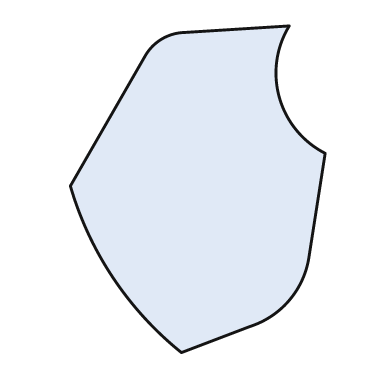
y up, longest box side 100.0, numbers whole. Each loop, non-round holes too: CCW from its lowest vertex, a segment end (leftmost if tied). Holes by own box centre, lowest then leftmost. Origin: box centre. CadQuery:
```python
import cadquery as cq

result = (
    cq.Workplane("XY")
    .moveTo(-5.0, -50.0)
    .lineTo(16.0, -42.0)
    .threePointArc((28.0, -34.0), (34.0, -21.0))
    .lineTo(39.0, 11.0)
    .threePointArc((25.0, 28.0), (28.0, 50.0))
    .lineTo(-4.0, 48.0)
    .threePointArc((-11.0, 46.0), (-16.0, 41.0))
    .lineTo(-39.0, 1.0)
    .threePointArc((-26.0, -27.0), (-5.0, -50.0))
    .close()
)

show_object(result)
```